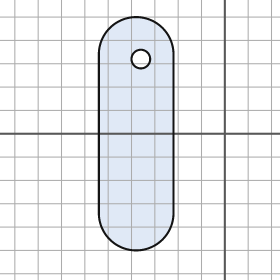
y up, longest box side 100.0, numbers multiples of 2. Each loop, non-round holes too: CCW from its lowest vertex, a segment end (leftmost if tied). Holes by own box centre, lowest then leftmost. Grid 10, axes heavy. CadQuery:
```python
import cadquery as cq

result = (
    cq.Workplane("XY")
    .moveTo(-54.0, -34.0)
    .threePointArc((-38.0, -50.0), (-22.0, -34.0))
    .lineTo(-22.0, 34.0)
    .threePointArc((-38.0, 50.0), (-54.0, 34.0))
    .close()
    .moveTo(-36.0, 32.0)
    .circle(4.0)
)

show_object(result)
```